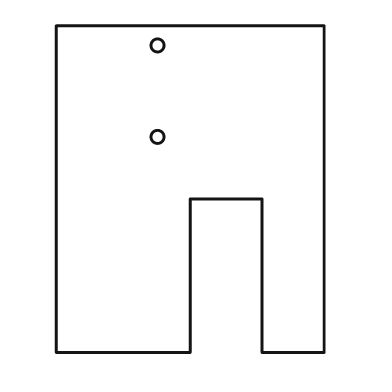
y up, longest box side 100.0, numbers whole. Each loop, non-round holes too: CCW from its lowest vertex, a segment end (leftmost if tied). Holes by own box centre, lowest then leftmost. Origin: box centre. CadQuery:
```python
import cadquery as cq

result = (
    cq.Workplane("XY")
    .moveTo(-41.0, -50.0)
    .lineTo(0.0, -50.0)
    .lineTo(0.0, -3.0)
    .lineTo(22.0, -3.0)
    .lineTo(22.0, -50.0)
    .lineTo(41.0, -50.0)
    .lineTo(41.0, 50.0)
    .lineTo(-41.0, 50.0)
    .close()
    .moveTo(-10.0, 16.0)
    .circle(2.0)
    .moveTo(-10.0, 44.0)
    .circle(2.0)
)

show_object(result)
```